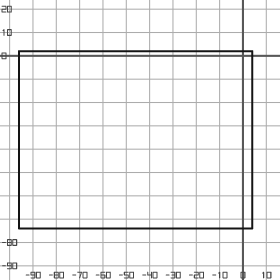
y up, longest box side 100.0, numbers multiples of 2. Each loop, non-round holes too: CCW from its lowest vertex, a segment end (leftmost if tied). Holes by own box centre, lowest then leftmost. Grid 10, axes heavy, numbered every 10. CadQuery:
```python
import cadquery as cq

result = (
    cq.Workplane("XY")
    .moveTo(-96.0, -74.0)
    .lineTo(4.0, -74.0)
    .lineTo(4.0, 2.0)
    .lineTo(-96.0, 2.0)
    .close()
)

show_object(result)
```